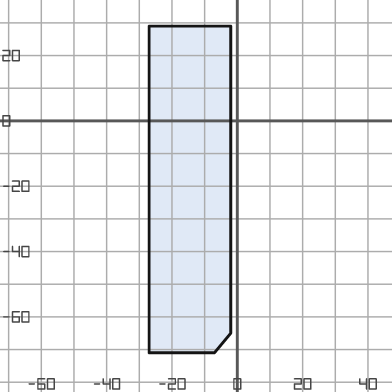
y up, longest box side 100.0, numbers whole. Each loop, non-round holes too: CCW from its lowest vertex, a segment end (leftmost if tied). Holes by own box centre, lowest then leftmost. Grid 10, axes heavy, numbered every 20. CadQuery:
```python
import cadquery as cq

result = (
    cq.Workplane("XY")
    .moveTo(-27.0, -71.0)
    .lineTo(-7.0, -71.0)
    .lineTo(-2.0, -65.0)
    .lineTo(-2.0, 29.0)
    .lineTo(-27.0, 29.0)
    .close()
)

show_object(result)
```